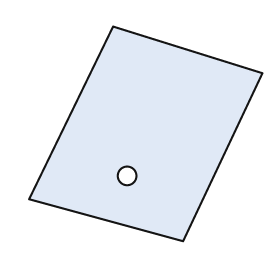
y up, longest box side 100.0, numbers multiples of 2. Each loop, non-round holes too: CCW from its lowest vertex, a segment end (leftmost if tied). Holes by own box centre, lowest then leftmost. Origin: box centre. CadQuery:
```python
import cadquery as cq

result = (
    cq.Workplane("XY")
    .moveTo(16.0, -46.0)
    .lineTo(50.0, 26.0)
    .lineTo(-14.0, 46.0)
    .lineTo(-50.0, -28.0)
    .close()
    .moveTo(-8.0, -18.0)
    .circle(4.0)
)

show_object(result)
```